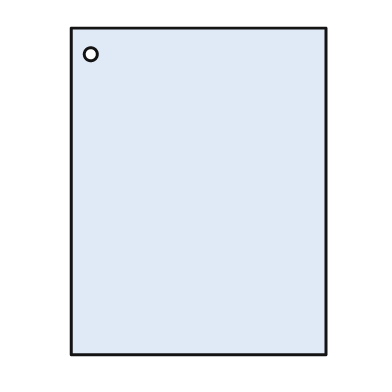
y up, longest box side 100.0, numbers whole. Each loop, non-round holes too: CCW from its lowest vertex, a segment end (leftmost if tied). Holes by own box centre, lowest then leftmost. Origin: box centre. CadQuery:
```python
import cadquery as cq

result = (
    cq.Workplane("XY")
    .moveTo(-39.0, -50.0)
    .lineTo(39.0, -50.0)
    .lineTo(39.0, 50.0)
    .lineTo(-39.0, 50.0)
    .close()
    .moveTo(-33.0, 42.0)
    .circle(2.0)
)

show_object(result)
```